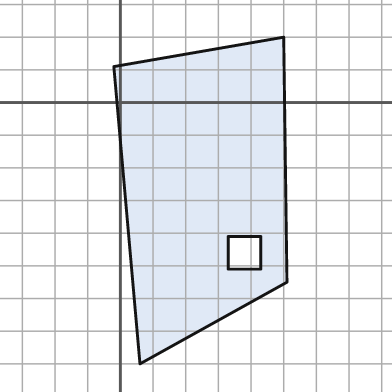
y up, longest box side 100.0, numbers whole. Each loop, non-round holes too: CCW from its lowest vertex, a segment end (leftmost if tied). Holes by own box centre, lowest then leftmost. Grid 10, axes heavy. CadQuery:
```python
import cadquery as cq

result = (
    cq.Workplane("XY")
    .moveTo(6.0, -80.0)
    .lineTo(51.0, -55.0)
    .lineTo(50.0, 20.0)
    .lineTo(-2.0, 11.0)
    .close()
    .moveTo(33.0, -51.0)
    .lineTo(43.0, -51.0)
    .lineTo(43.0, -41.0)
    .lineTo(33.0, -41.0)
    .close()
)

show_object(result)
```